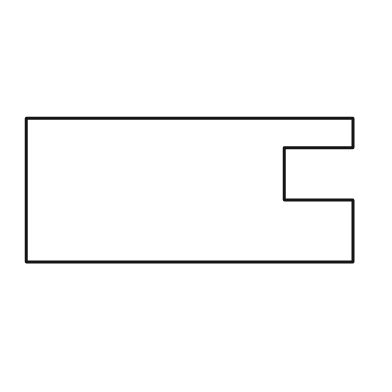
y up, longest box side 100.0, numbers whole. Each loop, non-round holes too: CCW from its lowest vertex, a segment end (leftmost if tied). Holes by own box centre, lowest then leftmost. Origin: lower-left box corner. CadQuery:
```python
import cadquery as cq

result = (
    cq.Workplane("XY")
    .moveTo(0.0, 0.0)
    .lineTo(100.0, 0.0)
    .lineTo(100.0, 19.0)
    .lineTo(79.0, 19.0)
    .lineTo(79.0, 35.0)
    .lineTo(100.0, 35.0)
    .lineTo(100.0, 44.0)
    .lineTo(0.0, 44.0)
    .close()
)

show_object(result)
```